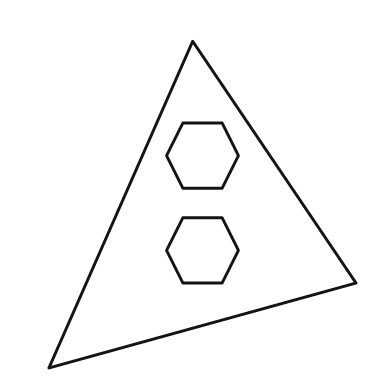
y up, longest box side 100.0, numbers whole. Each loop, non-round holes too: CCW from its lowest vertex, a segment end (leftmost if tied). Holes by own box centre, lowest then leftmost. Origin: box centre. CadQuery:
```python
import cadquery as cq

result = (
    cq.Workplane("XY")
    .moveTo(-47.0, -50.0)
    .lineTo(47.0, -24.0)
    .lineTo(-3.0, 50.0)
    .close()
    .moveTo(-6.0, -24.0)
    .lineTo(6.0, -24.0)
    .lineTo(11.0, -14.0)
    .lineTo(6.0, -4.0)
    .lineTo(-6.0, -4.0)
    .lineTo(-11.0, -14.0)
    .close()
    .moveTo(-6.0, 5.0)
    .lineTo(6.0, 5.0)
    .lineTo(11.0, 15.0)
    .lineTo(6.0, 25.0)
    .lineTo(-6.0, 25.0)
    .lineTo(-11.0, 15.0)
    .close()
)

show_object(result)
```